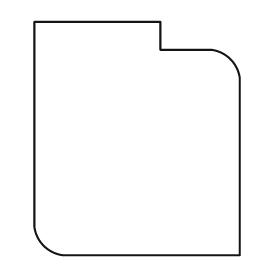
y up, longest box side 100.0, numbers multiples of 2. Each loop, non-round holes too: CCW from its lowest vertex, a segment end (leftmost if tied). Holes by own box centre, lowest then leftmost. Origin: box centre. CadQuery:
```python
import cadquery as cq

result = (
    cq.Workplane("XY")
    .moveTo(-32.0, -50.0)
    .lineTo(44.0, -50.0)
    .lineTo(44.0, 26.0)
    .threePointArc((40.0, 34.0), (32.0, 38.0))
    .lineTo(10.0, 38.0)
    .lineTo(10.0, 50.0)
    .lineTo(-44.0, 50.0)
    .lineTo(-44.0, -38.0)
    .threePointArc((-40.0, -46.0), (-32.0, -50.0))
    .close()
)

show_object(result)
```